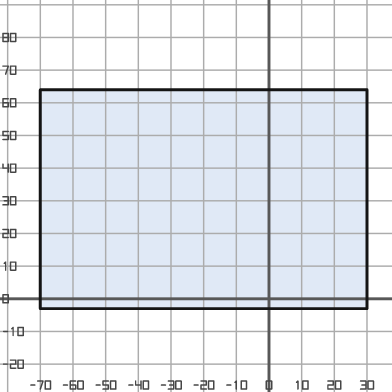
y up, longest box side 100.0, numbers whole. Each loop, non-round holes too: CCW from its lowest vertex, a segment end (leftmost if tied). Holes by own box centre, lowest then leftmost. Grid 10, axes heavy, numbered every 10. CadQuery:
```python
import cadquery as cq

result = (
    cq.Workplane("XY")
    .moveTo(-70.0, -3.0)
    .lineTo(30.0, -3.0)
    .lineTo(30.0, 64.0)
    .lineTo(-70.0, 64.0)
    .close()
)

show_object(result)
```